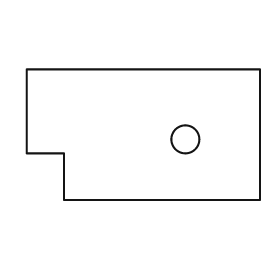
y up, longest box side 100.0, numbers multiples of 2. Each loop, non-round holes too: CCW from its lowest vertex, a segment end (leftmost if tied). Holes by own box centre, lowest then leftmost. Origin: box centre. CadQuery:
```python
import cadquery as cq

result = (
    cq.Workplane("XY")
    .moveTo(-34.0, -28.0)
    .lineTo(50.0, -28.0)
    .lineTo(50.0, 28.0)
    .lineTo(-50.0, 28.0)
    .lineTo(-50.0, -8.0)
    .lineTo(-34.0, -8.0)
    .close()
    .moveTo(18.0, -2.0)
    .circle(6.0)
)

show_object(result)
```